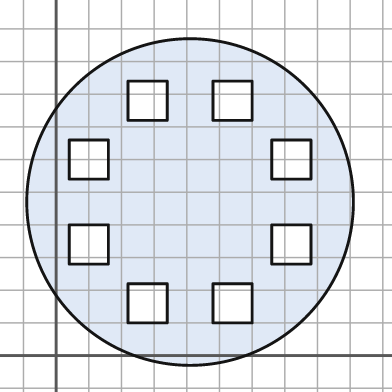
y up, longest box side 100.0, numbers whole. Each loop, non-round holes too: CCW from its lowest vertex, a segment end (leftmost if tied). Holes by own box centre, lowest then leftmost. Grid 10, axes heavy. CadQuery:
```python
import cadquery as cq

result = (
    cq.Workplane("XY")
    .moveTo(41.0, 47.0)
    .circle(50.0)
    .moveTo(22.0, 10.0)
    .lineTo(34.0, 10.0)
    .lineTo(34.0, 22.0)
    .lineTo(22.0, 22.0)
    .close()
    .moveTo(48.0, 10.0)
    .lineTo(60.0, 10.0)
    .lineTo(60.0, 22.0)
    .lineTo(48.0, 22.0)
    .close()
    .moveTo(4.0, 28.0)
    .lineTo(16.0, 28.0)
    .lineTo(16.0, 40.0)
    .lineTo(4.0, 40.0)
    .close()
    .moveTo(66.0, 28.0)
    .lineTo(78.0, 28.0)
    .lineTo(78.0, 40.0)
    .lineTo(66.0, 40.0)
    .close()
    .moveTo(4.0, 54.0)
    .lineTo(16.0, 54.0)
    .lineTo(16.0, 66.0)
    .lineTo(4.0, 66.0)
    .close()
    .moveTo(66.0, 54.0)
    .lineTo(78.0, 54.0)
    .lineTo(78.0, 66.0)
    .lineTo(66.0, 66.0)
    .close()
    .moveTo(22.0, 72.0)
    .lineTo(34.0, 72.0)
    .lineTo(34.0, 84.0)
    .lineTo(22.0, 84.0)
    .close()
    .moveTo(48.0, 72.0)
    .lineTo(60.0, 72.0)
    .lineTo(60.0, 84.0)
    .lineTo(48.0, 84.0)
    .close()
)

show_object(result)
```